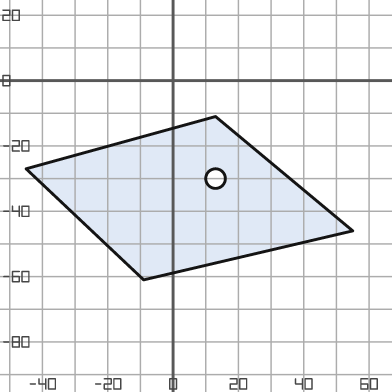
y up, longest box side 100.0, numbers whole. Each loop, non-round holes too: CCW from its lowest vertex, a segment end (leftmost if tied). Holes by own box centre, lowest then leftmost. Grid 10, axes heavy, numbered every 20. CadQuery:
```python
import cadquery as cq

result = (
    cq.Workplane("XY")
    .moveTo(-9.0, -61.0)
    .lineTo(55.0, -46.0)
    .lineTo(13.0, -11.0)
    .lineTo(-45.0, -27.0)
    .close()
    .moveTo(13.0, -30.0)
    .circle(3.0)
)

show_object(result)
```